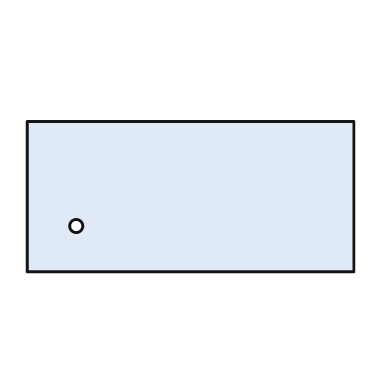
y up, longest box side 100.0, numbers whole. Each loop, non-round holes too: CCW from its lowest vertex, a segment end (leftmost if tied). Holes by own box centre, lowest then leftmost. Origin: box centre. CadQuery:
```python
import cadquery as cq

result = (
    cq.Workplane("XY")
    .moveTo(-50.0, -23.0)
    .lineTo(50.0, -23.0)
    .lineTo(50.0, 23.0)
    .lineTo(-50.0, 23.0)
    .close()
    .moveTo(-35.0, -9.0)
    .circle(2.0)
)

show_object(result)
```